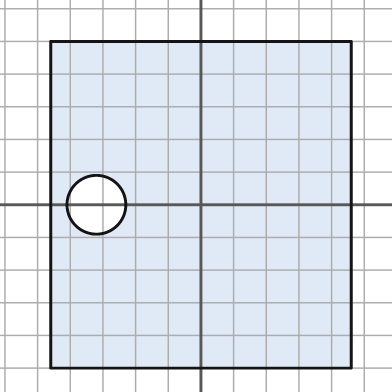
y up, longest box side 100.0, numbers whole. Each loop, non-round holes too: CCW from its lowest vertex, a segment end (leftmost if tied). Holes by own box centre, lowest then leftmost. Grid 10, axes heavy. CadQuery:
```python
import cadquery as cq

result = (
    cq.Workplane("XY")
    .moveTo(-46.0, -50.0)
    .lineTo(46.0, -50.0)
    .lineTo(46.0, 50.0)
    .lineTo(-46.0, 50.0)
    .close()
    .moveTo(-32.0, 0.0)
    .circle(9.0)
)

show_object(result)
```